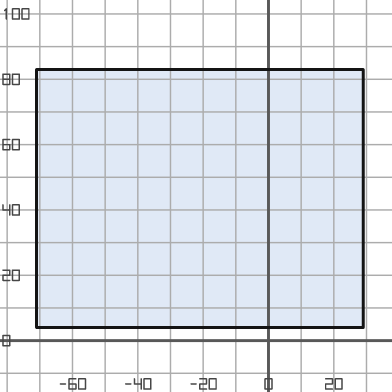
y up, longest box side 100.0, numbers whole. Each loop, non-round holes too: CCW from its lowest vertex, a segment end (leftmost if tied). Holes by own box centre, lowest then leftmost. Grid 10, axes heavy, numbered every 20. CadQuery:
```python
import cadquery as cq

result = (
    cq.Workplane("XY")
    .moveTo(-71.0, 4.0)
    .lineTo(29.0, 4.0)
    .lineTo(29.0, 83.0)
    .lineTo(-71.0, 83.0)
    .close()
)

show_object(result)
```